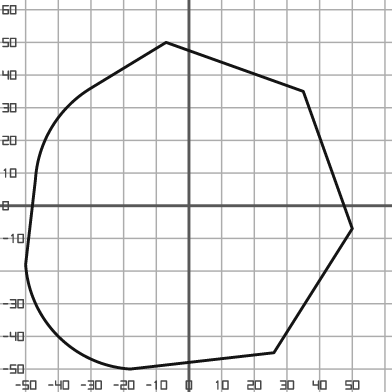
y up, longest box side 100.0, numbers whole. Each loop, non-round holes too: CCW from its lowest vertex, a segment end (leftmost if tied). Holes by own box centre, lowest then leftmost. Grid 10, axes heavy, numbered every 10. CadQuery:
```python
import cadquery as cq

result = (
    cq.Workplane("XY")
    .moveTo(-18.0, -50.0)
    .lineTo(26.0, -45.0)
    .lineTo(50.0, -7.0)
    .lineTo(35.0, 35.0)
    .lineTo(-7.0, 50.0)
    .lineTo(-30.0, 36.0)
    .threePointArc((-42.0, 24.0), (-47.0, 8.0))
    .lineTo(-50.0, -18.0)
    .threePointArc((-40.0, -40.0), (-18.0, -50.0))
    .close()
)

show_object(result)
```